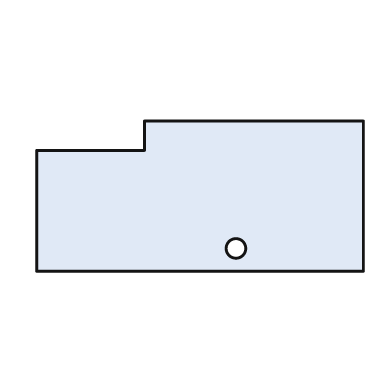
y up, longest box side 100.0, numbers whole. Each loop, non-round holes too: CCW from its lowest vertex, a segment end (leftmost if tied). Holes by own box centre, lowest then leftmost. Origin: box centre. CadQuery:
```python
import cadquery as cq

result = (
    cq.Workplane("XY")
    .moveTo(-50.0, -23.0)
    .lineTo(50.0, -23.0)
    .lineTo(50.0, 23.0)
    .lineTo(-17.0, 23.0)
    .lineTo(-17.0, 14.0)
    .lineTo(-50.0, 14.0)
    .close()
    .moveTo(11.0, -16.0)
    .circle(3.0)
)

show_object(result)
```